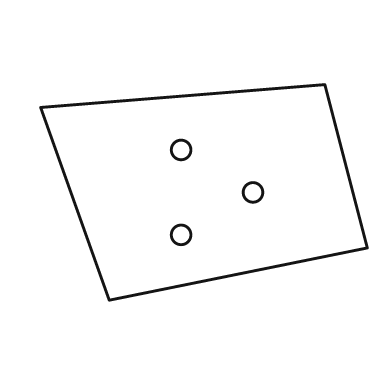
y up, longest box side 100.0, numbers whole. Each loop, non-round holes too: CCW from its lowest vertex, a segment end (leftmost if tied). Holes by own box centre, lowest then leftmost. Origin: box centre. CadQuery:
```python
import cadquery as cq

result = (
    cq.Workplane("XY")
    .moveTo(-29.0, -33.0)
    .lineTo(50.0, -17.0)
    .lineTo(37.0, 33.0)
    .lineTo(-50.0, 26.0)
    .close()
    .moveTo(-7.0, -13.0)
    .circle(3.0)
    .moveTo(15.0, 0.0)
    .circle(3.0)
    .moveTo(-7.0, 13.0)
    .circle(3.0)
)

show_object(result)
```